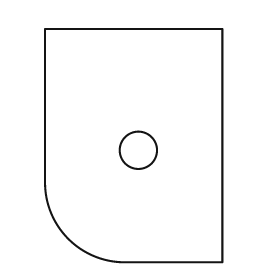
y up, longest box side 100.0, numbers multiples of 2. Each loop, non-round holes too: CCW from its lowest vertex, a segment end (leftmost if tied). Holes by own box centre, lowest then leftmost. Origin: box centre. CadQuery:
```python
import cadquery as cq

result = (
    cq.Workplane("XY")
    .moveTo(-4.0, -50.0)
    .lineTo(38.0, -50.0)
    .lineTo(38.0, 50.0)
    .lineTo(-38.0, 50.0)
    .lineTo(-38.0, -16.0)
    .threePointArc((-28.0, -40.0), (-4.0, -50.0))
    .close()
    .moveTo(2.0, -2.0)
    .circle(8.0)
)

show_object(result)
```